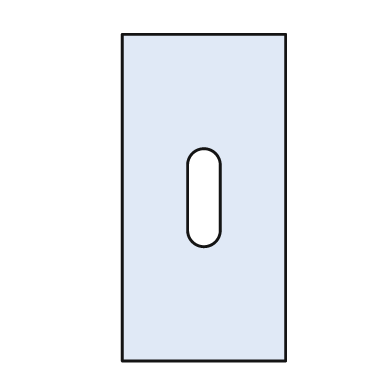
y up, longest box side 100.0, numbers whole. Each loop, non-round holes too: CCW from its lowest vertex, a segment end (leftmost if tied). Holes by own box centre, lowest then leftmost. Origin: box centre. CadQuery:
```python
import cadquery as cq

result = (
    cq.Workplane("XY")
    .moveTo(-25.0, -50.0)
    .lineTo(25.0, -50.0)
    .lineTo(25.0, 50.0)
    .lineTo(-25.0, 50.0)
    .close()
    .moveTo(-5.0, -10.0)
    .threePointArc((0.0, -15.0), (5.0, -10.0))
    .lineTo(5.0, 10.0)
    .threePointArc((0.0, 15.0), (-5.0, 10.0))
    .close()
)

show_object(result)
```